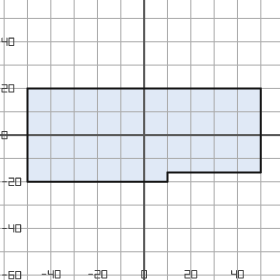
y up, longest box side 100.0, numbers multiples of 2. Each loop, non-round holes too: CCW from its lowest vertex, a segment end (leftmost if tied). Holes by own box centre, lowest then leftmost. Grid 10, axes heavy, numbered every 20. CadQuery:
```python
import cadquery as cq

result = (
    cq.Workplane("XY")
    .moveTo(-50.0, -20.0)
    .lineTo(10.0, -20.0)
    .lineTo(10.0, -16.0)
    .lineTo(50.0, -16.0)
    .lineTo(50.0, 20.0)
    .lineTo(-50.0, 20.0)
    .close()
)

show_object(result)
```